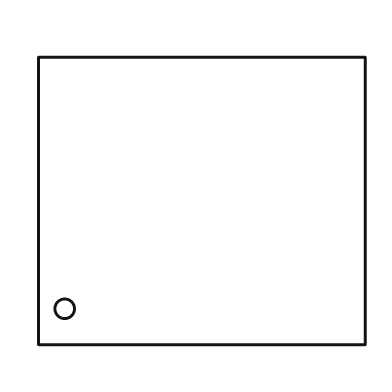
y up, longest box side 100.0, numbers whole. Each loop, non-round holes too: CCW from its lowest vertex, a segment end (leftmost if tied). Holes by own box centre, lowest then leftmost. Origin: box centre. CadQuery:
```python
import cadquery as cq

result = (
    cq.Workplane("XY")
    .moveTo(-50.0, -44.0)
    .lineTo(50.0, -44.0)
    .lineTo(50.0, 44.0)
    .lineTo(-50.0, 44.0)
    .close()
    .moveTo(-42.0, -33.0)
    .circle(3.0)
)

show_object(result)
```